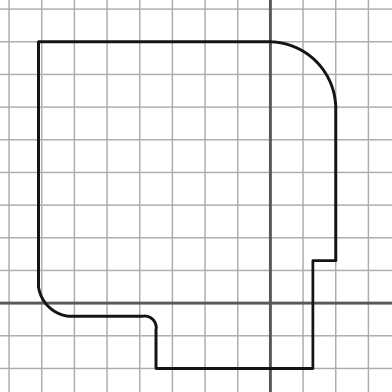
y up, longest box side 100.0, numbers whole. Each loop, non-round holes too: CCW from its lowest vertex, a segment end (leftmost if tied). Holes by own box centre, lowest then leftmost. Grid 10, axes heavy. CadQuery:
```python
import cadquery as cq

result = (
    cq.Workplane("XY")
    .moveTo(-35.0, -20.0)
    .lineTo(13.0, -20.0)
    .lineTo(13.0, 13.0)
    .lineTo(20.0, 13.0)
    .lineTo(20.0, 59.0)
    .threePointArc((14.0, 74.0), (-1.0, 80.0))
    .lineTo(-71.0, 80.0)
    .lineTo(-71.0, 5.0)
    .threePointArc((-68.0, -1.0), (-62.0, -4.0))
    .lineTo(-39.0, -4.0)
    .threePointArc((-36.0, -5.0), (-35.0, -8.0))
    .close()
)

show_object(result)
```